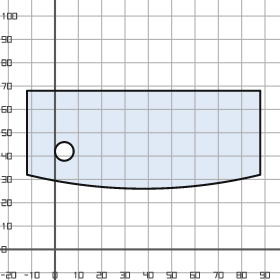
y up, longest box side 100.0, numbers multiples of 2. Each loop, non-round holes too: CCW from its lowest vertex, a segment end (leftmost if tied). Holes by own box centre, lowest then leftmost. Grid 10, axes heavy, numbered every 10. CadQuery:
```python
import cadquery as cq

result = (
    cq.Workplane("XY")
    .moveTo(-12.0, 32.0)
    .threePointArc((38.0, 26.0), (88.0, 32.0))
    .lineTo(88.0, 68.0)
    .lineTo(-12.0, 68.0)
    .close()
    .moveTo(4.0, 42.0)
    .circle(4.0)
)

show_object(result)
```